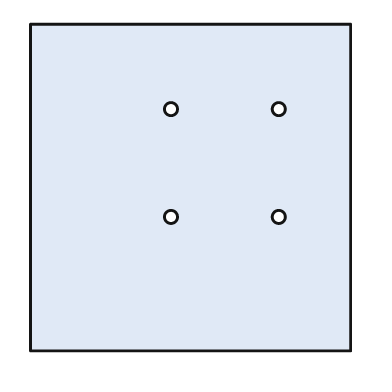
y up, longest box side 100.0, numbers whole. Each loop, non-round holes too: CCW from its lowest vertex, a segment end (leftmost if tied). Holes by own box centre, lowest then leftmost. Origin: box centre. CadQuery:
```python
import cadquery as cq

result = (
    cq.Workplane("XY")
    .moveTo(-49.0, -50.0)
    .lineTo(49.0, -50.0)
    .lineTo(49.0, 50.0)
    .lineTo(-49.0, 50.0)
    .close()
    .moveTo(-6.0, -9.0)
    .circle(2.0)
    .moveTo(27.0, -9.0)
    .circle(2.0)
    .moveTo(-6.0, 24.0)
    .circle(2.0)
    .moveTo(27.0, 24.0)
    .circle(2.0)
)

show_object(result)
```